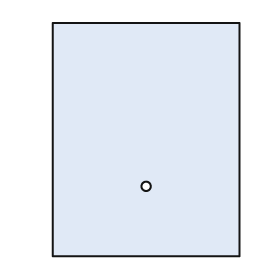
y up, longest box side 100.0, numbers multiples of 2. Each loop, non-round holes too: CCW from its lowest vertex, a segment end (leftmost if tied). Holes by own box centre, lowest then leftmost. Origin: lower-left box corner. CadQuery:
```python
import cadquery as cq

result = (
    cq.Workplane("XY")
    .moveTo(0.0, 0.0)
    .lineTo(80.0, 0.0)
    .lineTo(80.0, 100.0)
    .lineTo(0.0, 100.0)
    .close()
    .moveTo(40.0, 30.0)
    .circle(2.0)
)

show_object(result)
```